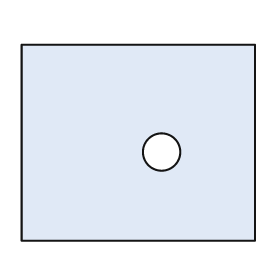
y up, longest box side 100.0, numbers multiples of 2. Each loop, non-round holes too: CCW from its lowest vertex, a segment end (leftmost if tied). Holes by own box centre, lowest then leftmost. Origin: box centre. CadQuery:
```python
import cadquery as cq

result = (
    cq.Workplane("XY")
    .moveTo(-50.0, -42.0)
    .lineTo(50.0, -42.0)
    .lineTo(50.0, 42.0)
    .lineTo(-50.0, 42.0)
    .close()
    .moveTo(10.0, -4.0)
    .circle(8.0)
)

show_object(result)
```